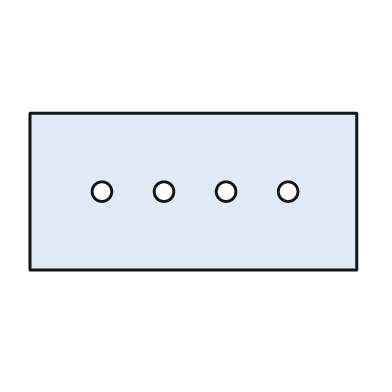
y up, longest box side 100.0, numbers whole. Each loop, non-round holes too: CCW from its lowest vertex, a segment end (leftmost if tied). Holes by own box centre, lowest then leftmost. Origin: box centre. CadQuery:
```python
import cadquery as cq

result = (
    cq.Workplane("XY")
    .moveTo(-50.0, -24.0)
    .lineTo(50.0, -24.0)
    .lineTo(50.0, 24.0)
    .lineTo(-50.0, 24.0)
    .close()
    .moveTo(-28.0, 0.0)
    .circle(3.0)
    .moveTo(-9.0, 0.0)
    .circle(3.0)
    .moveTo(10.0, 0.0)
    .circle(3.0)
    .moveTo(29.0, 0.0)
    .circle(3.0)
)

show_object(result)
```